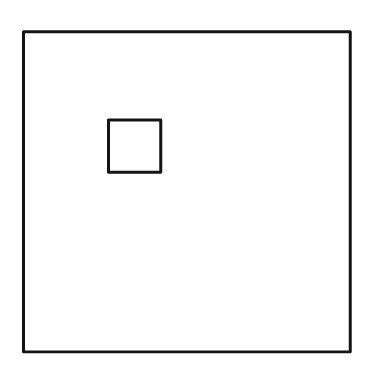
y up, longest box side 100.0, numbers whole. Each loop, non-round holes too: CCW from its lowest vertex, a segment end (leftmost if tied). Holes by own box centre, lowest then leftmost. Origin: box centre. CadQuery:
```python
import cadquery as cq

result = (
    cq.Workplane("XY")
    .moveTo(-50.0, -49.0)
    .lineTo(50.0, -49.0)
    .lineTo(50.0, 49.0)
    .lineTo(-50.0, 49.0)
    .close()
    .moveTo(-24.0, 6.0)
    .lineTo(-8.0, 6.0)
    .lineTo(-8.0, 22.0)
    .lineTo(-24.0, 22.0)
    .close()
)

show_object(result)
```